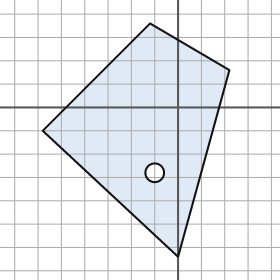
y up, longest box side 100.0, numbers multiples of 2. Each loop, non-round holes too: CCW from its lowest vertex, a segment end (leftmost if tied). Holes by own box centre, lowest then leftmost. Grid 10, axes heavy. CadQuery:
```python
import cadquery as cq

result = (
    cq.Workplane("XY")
    .moveTo(0.0, -64.0)
    .lineTo(22.0, 16.0)
    .lineTo(-12.0, 36.0)
    .lineTo(-58.0, -10.0)
    .close()
    .moveTo(-10.0, -28.0)
    .circle(4.0)
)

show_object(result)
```